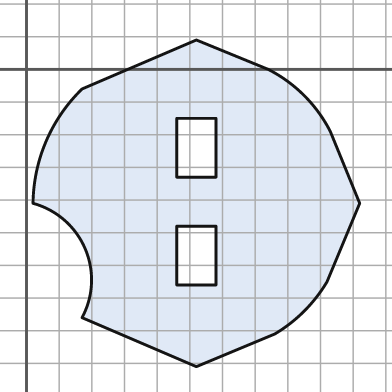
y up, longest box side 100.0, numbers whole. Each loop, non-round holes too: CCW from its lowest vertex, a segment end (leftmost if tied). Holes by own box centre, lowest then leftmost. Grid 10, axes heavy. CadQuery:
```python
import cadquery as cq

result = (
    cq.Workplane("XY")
    .moveTo(52.0, -91.0)
    .lineTo(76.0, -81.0)
    .threePointArc((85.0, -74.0), (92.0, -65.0))
    .lineTo(102.0, -41.0)
    .lineTo(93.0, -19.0)
    .threePointArc((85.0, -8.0), (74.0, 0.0))
    .lineTo(52.0, 9.0)
    .lineTo(17.0, -6.0)
    .threePointArc((6.0, -22.0), (2.0, -41.0))
    .threePointArc((18.0, -55.0), (17.0, -76.0))
    .close()
    .moveTo(46.0, -66.0)
    .lineTo(58.0, -66.0)
    .lineTo(58.0, -48.0)
    .lineTo(46.0, -48.0)
    .close()
    .moveTo(46.0, -33.0)
    .lineTo(58.0, -33.0)
    .lineTo(58.0, -15.0)
    .lineTo(46.0, -15.0)
    .close()
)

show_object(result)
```